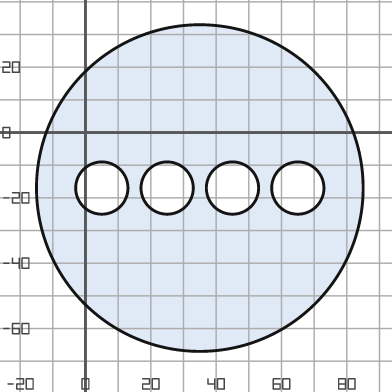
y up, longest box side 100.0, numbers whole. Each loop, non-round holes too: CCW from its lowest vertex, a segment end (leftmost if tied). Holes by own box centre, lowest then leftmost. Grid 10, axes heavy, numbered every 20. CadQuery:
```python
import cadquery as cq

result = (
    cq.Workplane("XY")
    .moveTo(35.0, -17.0)
    .circle(50.0)
    .moveTo(5.0, -17.0)
    .circle(8.0)
    .moveTo(25.0, -17.0)
    .circle(8.0)
    .moveTo(45.0, -17.0)
    .circle(8.0)
    .moveTo(65.0, -17.0)
    .circle(8.0)
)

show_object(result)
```